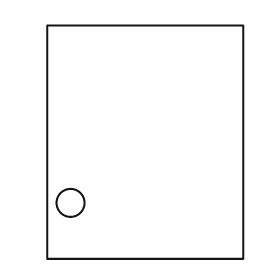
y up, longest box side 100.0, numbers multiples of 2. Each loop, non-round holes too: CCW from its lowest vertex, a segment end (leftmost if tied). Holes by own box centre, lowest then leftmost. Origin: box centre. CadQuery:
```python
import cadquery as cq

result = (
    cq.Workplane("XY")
    .moveTo(-42.0, -50.0)
    .lineTo(42.0, -50.0)
    .lineTo(42.0, 50.0)
    .lineTo(-42.0, 50.0)
    .close()
    .moveTo(-32.0, -26.0)
    .circle(6.0)
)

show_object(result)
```